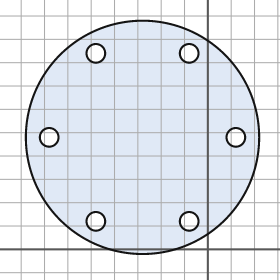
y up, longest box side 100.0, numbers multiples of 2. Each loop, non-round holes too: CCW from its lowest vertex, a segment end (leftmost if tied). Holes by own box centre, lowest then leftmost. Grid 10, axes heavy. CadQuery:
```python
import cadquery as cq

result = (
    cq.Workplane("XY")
    .moveTo(-28.0, 48.0)
    .circle(50.0)
    .moveTo(-48.0, 12.0)
    .circle(4.0)
    .moveTo(-8.0, 12.0)
    .circle(4.0)
    .moveTo(-68.0, 48.0)
    .circle(4.0)
    .moveTo(12.0, 48.0)
    .circle(4.0)
    .moveTo(-48.0, 84.0)
    .circle(4.0)
    .moveTo(-8.0, 84.0)
    .circle(4.0)
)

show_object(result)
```